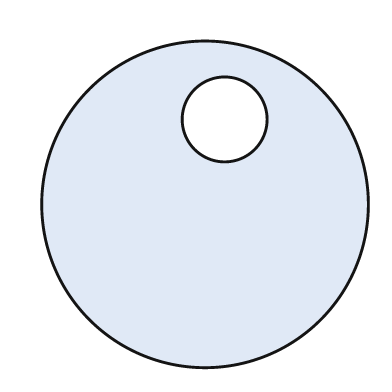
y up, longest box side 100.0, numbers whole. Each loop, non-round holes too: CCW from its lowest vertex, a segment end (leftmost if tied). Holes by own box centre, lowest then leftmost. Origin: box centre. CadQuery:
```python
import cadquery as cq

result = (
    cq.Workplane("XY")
    .moveTo(0.0, 0.0)
    .circle(50.0)
    .moveTo(6.0, 26.0)
    .circle(13.0)
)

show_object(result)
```